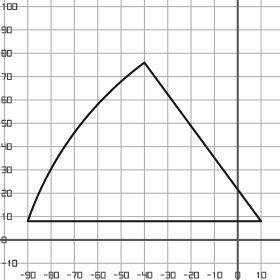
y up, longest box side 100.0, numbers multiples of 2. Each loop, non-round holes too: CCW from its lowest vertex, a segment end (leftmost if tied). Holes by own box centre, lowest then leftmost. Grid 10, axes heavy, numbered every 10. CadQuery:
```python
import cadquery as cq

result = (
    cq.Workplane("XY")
    .moveTo(-90.0, 8.0)
    .lineTo(10.0, 8.0)
    .lineTo(-40.0, 76.0)
    .threePointArc((-70.0, 46.0), (-90.0, 8.0))
    .close()
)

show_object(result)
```